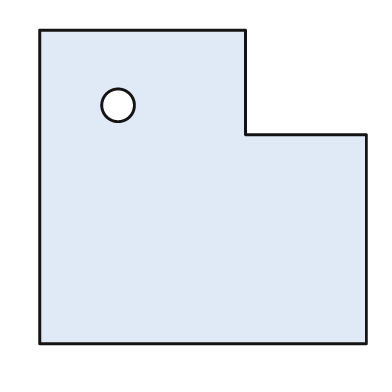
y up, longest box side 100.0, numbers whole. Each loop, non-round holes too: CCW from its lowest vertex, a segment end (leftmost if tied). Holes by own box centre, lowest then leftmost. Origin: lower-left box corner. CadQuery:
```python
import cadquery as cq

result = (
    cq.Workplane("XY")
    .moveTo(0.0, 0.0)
    .lineTo(100.0, 0.0)
    .lineTo(100.0, 64.0)
    .lineTo(63.0, 64.0)
    .lineTo(63.0, 96.0)
    .lineTo(0.0, 96.0)
    .close()
    .moveTo(24.0, 73.0)
    .circle(5.0)
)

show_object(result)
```